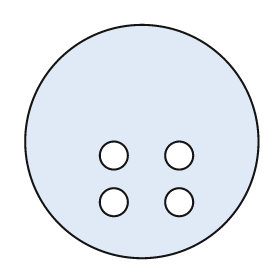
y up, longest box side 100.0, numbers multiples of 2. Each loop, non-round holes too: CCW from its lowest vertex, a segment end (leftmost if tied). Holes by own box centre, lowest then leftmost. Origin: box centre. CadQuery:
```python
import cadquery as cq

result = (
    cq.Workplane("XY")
    .moveTo(0.0, 0.0)
    .circle(50.0)
    .moveTo(-12.0, -26.0)
    .circle(6.0)
    .moveTo(16.0, -26.0)
    .circle(6.0)
    .moveTo(-12.0, -6.0)
    .circle(6.0)
    .moveTo(16.0, -6.0)
    .circle(6.0)
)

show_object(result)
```